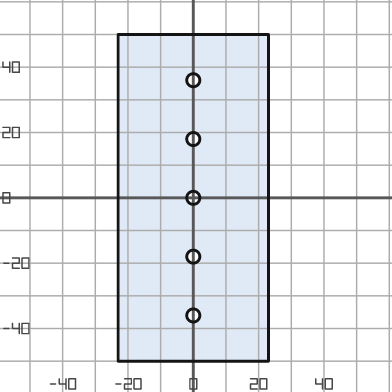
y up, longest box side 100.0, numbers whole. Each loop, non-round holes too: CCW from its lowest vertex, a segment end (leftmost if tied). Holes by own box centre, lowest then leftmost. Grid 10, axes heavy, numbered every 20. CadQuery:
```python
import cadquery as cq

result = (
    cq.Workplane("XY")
    .moveTo(-23.0, -50.0)
    .lineTo(23.0, -50.0)
    .lineTo(23.0, 50.0)
    .lineTo(-23.0, 50.0)
    .close()
    .moveTo(0.0, -36.0)
    .circle(2.0)
    .moveTo(0.0, -18.0)
    .circle(2.0)
    .moveTo(0.0, 0.0)
    .circle(2.0)
    .moveTo(0.0, 18.0)
    .circle(2.0)
    .moveTo(0.0, 36.0)
    .circle(2.0)
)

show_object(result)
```